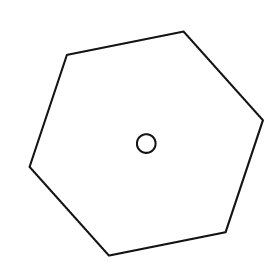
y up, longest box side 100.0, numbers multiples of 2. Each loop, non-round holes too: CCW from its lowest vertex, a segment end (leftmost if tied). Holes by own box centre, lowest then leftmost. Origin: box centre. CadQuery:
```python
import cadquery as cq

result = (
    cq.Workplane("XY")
    .moveTo(-16.0, -48.0)
    .lineTo(34.0, -38.0)
    .lineTo(50.0, 10.0)
    .lineTo(16.0, 48.0)
    .lineTo(-34.0, 38.0)
    .lineTo(-50.0, -10.0)
    .close()
    .moveTo(0.0, 0.0)
    .circle(4.0)
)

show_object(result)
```